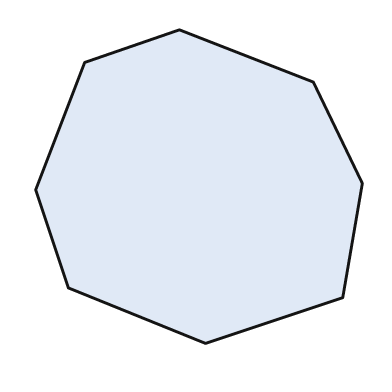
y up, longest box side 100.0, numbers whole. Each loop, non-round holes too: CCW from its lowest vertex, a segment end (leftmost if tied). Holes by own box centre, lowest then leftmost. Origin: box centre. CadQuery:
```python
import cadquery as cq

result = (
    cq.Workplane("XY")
    .moveTo(2.0, -48.0)
    .lineTo(44.0, -34.0)
    .lineTo(50.0, 1.0)
    .lineTo(35.0, 32.0)
    .lineTo(-6.0, 48.0)
    .lineTo(-35.0, 38.0)
    .lineTo(-50.0, -1.0)
    .lineTo(-40.0, -31.0)
    .close()
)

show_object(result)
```